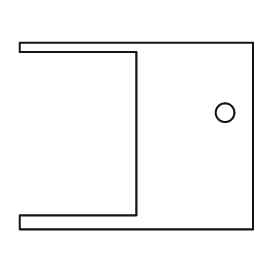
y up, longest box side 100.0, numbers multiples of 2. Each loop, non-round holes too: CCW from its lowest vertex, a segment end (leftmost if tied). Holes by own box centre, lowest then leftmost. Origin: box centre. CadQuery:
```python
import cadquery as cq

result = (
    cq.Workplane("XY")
    .moveTo(-50.0, -40.0)
    .lineTo(50.0, -40.0)
    .lineTo(50.0, 40.0)
    .lineTo(-50.0, 40.0)
    .lineTo(-50.0, 36.0)
    .lineTo(0.0, 36.0)
    .lineTo(0.0, -34.0)
    .lineTo(-50.0, -34.0)
    .close()
    .moveTo(38.0, 10.0)
    .circle(4.0)
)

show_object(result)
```